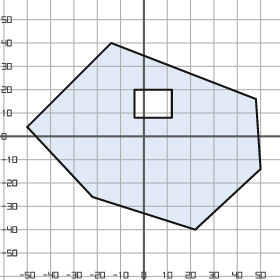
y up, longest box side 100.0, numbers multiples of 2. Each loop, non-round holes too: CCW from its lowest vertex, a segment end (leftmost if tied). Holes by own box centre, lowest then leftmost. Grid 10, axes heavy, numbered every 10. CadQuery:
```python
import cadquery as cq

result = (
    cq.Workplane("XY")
    .moveTo(22.0, -40.0)
    .lineTo(50.0, -14.0)
    .lineTo(48.0, 16.0)
    .lineTo(-14.0, 40.0)
    .lineTo(-50.0, 4.0)
    .lineTo(-22.0, -26.0)
    .close()
    .moveTo(-4.0, 8.0)
    .lineTo(12.0, 8.0)
    .lineTo(12.0, 20.0)
    .lineTo(-4.0, 20.0)
    .close()
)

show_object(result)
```